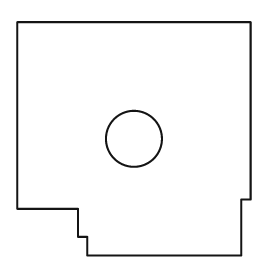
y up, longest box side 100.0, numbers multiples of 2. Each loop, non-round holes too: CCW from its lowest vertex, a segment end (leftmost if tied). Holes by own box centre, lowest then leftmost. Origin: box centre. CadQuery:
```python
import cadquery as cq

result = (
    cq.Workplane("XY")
    .moveTo(-20.0, -50.0)
    .lineTo(46.0, -50.0)
    .lineTo(46.0, -26.0)
    .lineTo(50.0, -26.0)
    .lineTo(50.0, 50.0)
    .lineTo(-50.0, 50.0)
    .lineTo(-50.0, -30.0)
    .lineTo(-24.0, -30.0)
    .lineTo(-24.0, -42.0)
    .lineTo(-20.0, -42.0)
    .close()
    .moveTo(0.0, 0.0)
    .circle(12.0)
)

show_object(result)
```